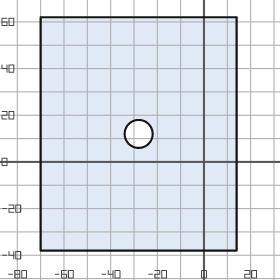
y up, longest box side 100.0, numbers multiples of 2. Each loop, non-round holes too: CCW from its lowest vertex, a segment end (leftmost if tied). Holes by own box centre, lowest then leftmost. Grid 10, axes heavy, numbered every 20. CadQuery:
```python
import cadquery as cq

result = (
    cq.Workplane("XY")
    .moveTo(-70.0, -38.0)
    .lineTo(14.0, -38.0)
    .lineTo(14.0, 62.0)
    .lineTo(-70.0, 62.0)
    .close()
    .moveTo(-28.0, 12.0)
    .circle(6.0)
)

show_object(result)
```